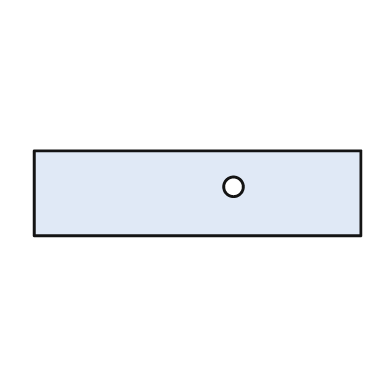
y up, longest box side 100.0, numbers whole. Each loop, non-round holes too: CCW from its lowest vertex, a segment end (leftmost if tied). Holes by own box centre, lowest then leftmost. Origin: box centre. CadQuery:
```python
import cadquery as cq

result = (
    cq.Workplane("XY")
    .moveTo(-50.0, -13.0)
    .lineTo(50.0, -13.0)
    .lineTo(50.0, 13.0)
    .lineTo(-50.0, 13.0)
    .close()
    .moveTo(11.0, 2.0)
    .circle(3.0)
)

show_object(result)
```